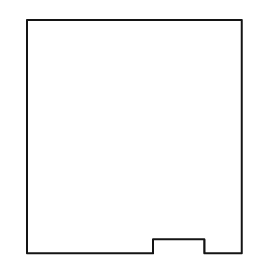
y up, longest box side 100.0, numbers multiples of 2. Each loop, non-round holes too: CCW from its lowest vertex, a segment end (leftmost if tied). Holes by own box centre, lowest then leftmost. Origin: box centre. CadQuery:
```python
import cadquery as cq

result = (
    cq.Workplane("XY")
    .moveTo(-46.0, -50.0)
    .lineTo(8.0, -50.0)
    .lineTo(8.0, -44.0)
    .lineTo(30.0, -44.0)
    .lineTo(30.0, -50.0)
    .lineTo(46.0, -50.0)
    .lineTo(46.0, 50.0)
    .lineTo(-46.0, 50.0)
    .close()
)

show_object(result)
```